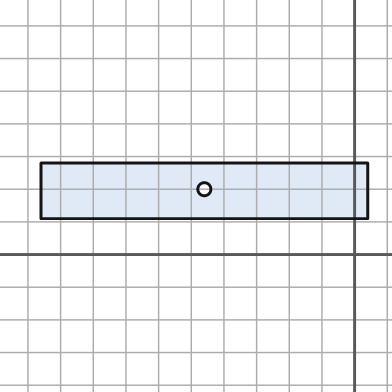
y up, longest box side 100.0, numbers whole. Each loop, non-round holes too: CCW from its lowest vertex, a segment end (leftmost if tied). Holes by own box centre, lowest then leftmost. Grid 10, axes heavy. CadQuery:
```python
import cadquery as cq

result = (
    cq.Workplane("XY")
    .moveTo(-96.0, 11.0)
    .lineTo(4.0, 11.0)
    .lineTo(4.0, 28.0)
    .lineTo(-96.0, 28.0)
    .close()
    .moveTo(-46.0, 20.0)
    .circle(2.0)
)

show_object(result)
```